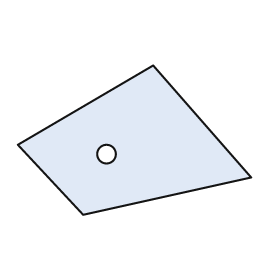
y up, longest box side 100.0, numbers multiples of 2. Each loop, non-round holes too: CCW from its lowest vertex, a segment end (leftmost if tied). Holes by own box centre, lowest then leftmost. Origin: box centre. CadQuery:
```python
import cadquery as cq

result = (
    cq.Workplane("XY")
    .moveTo(-22.0, -32.0)
    .lineTo(50.0, -16.0)
    .lineTo(8.0, 32.0)
    .lineTo(-50.0, -2.0)
    .close()
    .moveTo(-12.0, -6.0)
    .circle(4.0)
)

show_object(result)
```